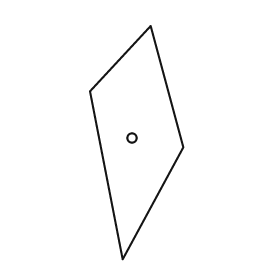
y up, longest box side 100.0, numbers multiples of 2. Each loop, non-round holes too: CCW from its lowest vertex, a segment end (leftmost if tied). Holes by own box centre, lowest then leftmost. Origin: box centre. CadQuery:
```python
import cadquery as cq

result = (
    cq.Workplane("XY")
    .moveTo(-6.0, -50.0)
    .lineTo(20.0, -2.0)
    .lineTo(6.0, 50.0)
    .lineTo(-20.0, 22.0)
    .close()
    .moveTo(-2.0, 2.0)
    .circle(2.0)
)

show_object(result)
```